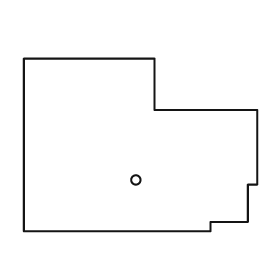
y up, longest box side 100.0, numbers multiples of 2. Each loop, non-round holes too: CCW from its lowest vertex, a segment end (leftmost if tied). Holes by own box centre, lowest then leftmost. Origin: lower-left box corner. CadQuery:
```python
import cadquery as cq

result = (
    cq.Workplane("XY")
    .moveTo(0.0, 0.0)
    .lineTo(80.0, 0.0)
    .lineTo(80.0, 4.0)
    .lineTo(96.0, 4.0)
    .lineTo(96.0, 20.0)
    .lineTo(100.0, 20.0)
    .lineTo(100.0, 52.0)
    .lineTo(56.0, 52.0)
    .lineTo(56.0, 74.0)
    .lineTo(0.0, 74.0)
    .close()
    .moveTo(48.0, 22.0)
    .circle(2.0)
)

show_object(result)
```